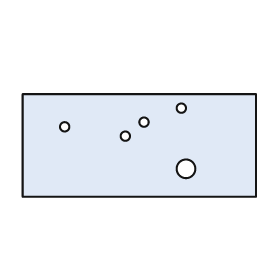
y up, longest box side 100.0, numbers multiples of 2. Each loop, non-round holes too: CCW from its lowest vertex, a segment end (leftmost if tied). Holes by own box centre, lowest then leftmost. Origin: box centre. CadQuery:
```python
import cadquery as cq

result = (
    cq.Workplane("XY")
    .moveTo(-50.0, -22.0)
    .lineTo(50.0, -22.0)
    .lineTo(50.0, 22.0)
    .lineTo(-50.0, 22.0)
    .close()
    .moveTo(20.0, -10.0)
    .circle(4.0)
    .moveTo(-6.0, 4.0)
    .circle(2.0)
    .moveTo(-32.0, 8.0)
    .circle(2.0)
    .moveTo(2.0, 10.0)
    .circle(2.0)
    .moveTo(18.0, 16.0)
    .circle(2.0)
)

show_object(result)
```